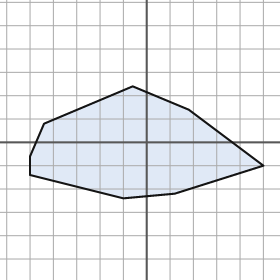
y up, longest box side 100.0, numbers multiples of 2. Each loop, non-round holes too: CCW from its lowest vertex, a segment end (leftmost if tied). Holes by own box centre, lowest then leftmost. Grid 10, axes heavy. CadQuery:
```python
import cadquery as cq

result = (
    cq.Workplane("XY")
    .moveTo(-10.0, -24.0)
    .lineTo(12.0, -22.0)
    .lineTo(50.0, -10.0)
    .lineTo(18.0, 14.0)
    .lineTo(-6.0, 24.0)
    .lineTo(-44.0, 8.0)
    .lineTo(-50.0, -6.0)
    .lineTo(-50.0, -14.0)
    .close()
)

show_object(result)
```